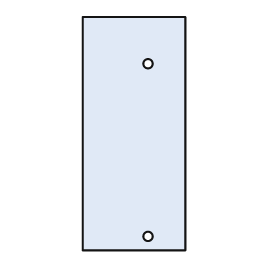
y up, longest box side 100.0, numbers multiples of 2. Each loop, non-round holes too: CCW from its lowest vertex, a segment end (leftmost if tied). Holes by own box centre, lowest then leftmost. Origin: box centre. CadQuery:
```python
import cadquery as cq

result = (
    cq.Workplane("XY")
    .moveTo(-22.0, -50.0)
    .lineTo(22.0, -50.0)
    .lineTo(22.0, 50.0)
    .lineTo(-22.0, 50.0)
    .close()
    .moveTo(6.0, -44.0)
    .circle(2.0)
    .moveTo(6.0, 30.0)
    .circle(2.0)
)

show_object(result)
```